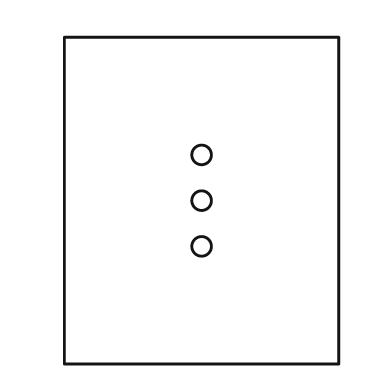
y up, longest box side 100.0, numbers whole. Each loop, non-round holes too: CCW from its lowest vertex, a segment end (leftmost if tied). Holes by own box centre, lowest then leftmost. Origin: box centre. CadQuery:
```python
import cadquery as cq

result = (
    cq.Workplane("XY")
    .moveTo(-42.0, -50.0)
    .lineTo(42.0, -50.0)
    .lineTo(42.0, 50.0)
    .lineTo(-42.0, 50.0)
    .close()
    .moveTo(0.0, -14.0)
    .circle(3.0)
    .moveTo(0.0, 0.0)
    .circle(3.0)
    .moveTo(0.0, 14.0)
    .circle(3.0)
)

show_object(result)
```